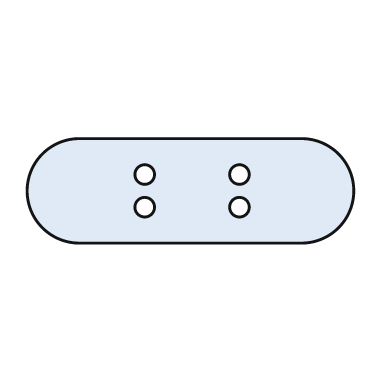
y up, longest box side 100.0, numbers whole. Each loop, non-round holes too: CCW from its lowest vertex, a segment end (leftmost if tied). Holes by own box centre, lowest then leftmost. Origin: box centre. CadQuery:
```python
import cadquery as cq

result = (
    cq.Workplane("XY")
    .moveTo(-34.0, -16.0)
    .lineTo(34.0, -16.0)
    .threePointArc((50.0, 0.0), (34.0, 16.0))
    .lineTo(-34.0, 16.0)
    .threePointArc((-50.0, 0.0), (-34.0, -16.0))
    .close()
    .moveTo(-14.0, -5.0)
    .circle(3.0)
    .moveTo(15.0, -5.0)
    .circle(3.0)
    .moveTo(-14.0, 5.0)
    .circle(3.0)
    .moveTo(15.0, 5.0)
    .circle(3.0)
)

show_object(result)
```